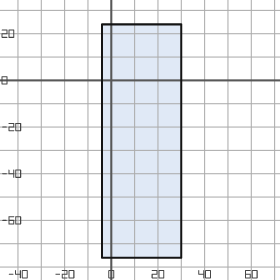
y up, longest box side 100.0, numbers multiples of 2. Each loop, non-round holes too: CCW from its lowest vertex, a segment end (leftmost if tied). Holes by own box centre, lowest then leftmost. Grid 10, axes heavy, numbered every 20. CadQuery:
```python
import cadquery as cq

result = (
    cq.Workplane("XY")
    .moveTo(-4.0, -76.0)
    .lineTo(30.0, -76.0)
    .lineTo(30.0, 24.0)
    .lineTo(-4.0, 24.0)
    .close()
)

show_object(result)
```